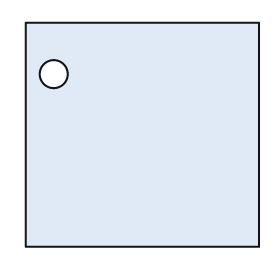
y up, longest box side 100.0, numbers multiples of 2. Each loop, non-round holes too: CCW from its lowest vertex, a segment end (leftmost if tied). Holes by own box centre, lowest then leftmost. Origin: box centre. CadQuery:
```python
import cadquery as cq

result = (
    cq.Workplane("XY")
    .moveTo(-50.0, -48.0)
    .lineTo(50.0, -48.0)
    .lineTo(50.0, 48.0)
    .lineTo(-50.0, 48.0)
    .close()
    .moveTo(-38.0, 26.0)
    .circle(6.0)
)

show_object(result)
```